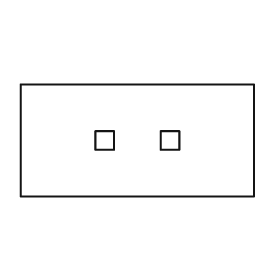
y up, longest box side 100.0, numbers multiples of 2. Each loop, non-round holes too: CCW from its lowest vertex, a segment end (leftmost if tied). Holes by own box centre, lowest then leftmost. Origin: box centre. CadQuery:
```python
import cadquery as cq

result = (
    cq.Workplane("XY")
    .moveTo(-50.0, -24.0)
    .lineTo(50.0, -24.0)
    .lineTo(50.0, 24.0)
    .lineTo(-50.0, 24.0)
    .close()
    .moveTo(-18.0, -4.0)
    .lineTo(-10.0, -4.0)
    .lineTo(-10.0, 4.0)
    .lineTo(-18.0, 4.0)
    .close()
    .moveTo(10.0, -4.0)
    .lineTo(18.0, -4.0)
    .lineTo(18.0, 4.0)
    .lineTo(10.0, 4.0)
    .close()
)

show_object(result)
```